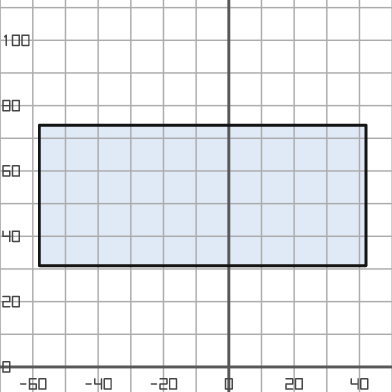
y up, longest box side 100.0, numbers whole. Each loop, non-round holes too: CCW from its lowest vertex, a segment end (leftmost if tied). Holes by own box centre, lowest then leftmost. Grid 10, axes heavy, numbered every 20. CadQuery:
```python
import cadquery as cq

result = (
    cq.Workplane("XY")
    .moveTo(-58.0, 31.0)
    .lineTo(42.0, 31.0)
    .lineTo(42.0, 74.0)
    .lineTo(-58.0, 74.0)
    .close()
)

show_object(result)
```